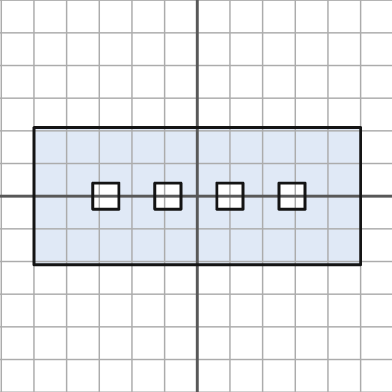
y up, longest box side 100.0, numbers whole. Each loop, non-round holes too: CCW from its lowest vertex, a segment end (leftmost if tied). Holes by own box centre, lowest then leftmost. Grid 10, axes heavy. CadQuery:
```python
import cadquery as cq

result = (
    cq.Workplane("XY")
    .moveTo(-50.0, -21.0)
    .lineTo(50.0, -21.0)
    .lineTo(50.0, 21.0)
    .lineTo(-50.0, 21.0)
    .close()
    .moveTo(-32.0, -4.0)
    .lineTo(-24.0, -4.0)
    .lineTo(-24.0, 4.0)
    .lineTo(-32.0, 4.0)
    .close()
    .moveTo(-13.0, -4.0)
    .lineTo(-5.0, -4.0)
    .lineTo(-5.0, 4.0)
    .lineTo(-13.0, 4.0)
    .close()
    .moveTo(6.0, -4.0)
    .lineTo(14.0, -4.0)
    .lineTo(14.0, 4.0)
    .lineTo(6.0, 4.0)
    .close()
    .moveTo(25.0, -4.0)
    .lineTo(33.0, -4.0)
    .lineTo(33.0, 4.0)
    .lineTo(25.0, 4.0)
    .close()
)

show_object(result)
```